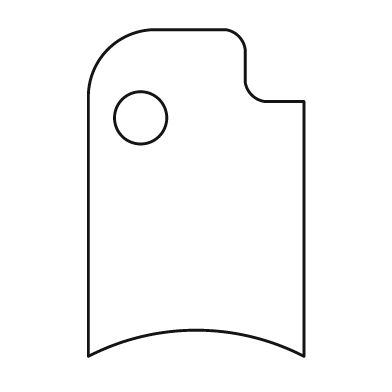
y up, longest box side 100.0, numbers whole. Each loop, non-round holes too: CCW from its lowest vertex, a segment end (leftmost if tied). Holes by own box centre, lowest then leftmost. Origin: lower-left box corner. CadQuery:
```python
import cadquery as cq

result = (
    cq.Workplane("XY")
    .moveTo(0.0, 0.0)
    .threePointArc((33.0, 8.0), (66.0, 0.0))
    .lineTo(66.0, 78.0)
    .lineTo(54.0, 78.0)
    .threePointArc((50.0, 80.0), (48.0, 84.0))
    .lineTo(48.0, 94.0)
    .threePointArc((46.0, 98.0), (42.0, 100.0))
    .lineTo(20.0, 100.0)
    .threePointArc((6.0, 94.0), (0.0, 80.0))
    .close()
    .moveTo(16.0, 73.0)
    .circle(8.0)
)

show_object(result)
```